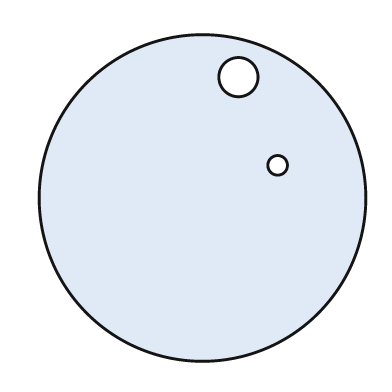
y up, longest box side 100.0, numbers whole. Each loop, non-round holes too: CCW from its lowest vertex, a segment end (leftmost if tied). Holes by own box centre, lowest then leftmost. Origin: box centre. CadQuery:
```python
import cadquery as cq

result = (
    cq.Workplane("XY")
    .moveTo(0.0, 0.0)
    .circle(50.0)
    .moveTo(23.0, 10.0)
    .circle(3.0)
    .moveTo(11.0, 37.0)
    .circle(6.0)
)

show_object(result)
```